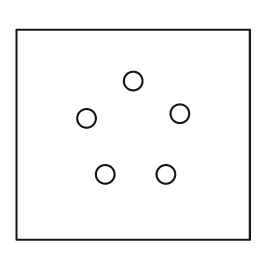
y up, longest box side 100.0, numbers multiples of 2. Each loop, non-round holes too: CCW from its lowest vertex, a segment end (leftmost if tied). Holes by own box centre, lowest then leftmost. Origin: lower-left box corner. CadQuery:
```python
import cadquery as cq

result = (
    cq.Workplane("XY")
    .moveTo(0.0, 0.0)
    .lineTo(100.0, 0.0)
    .lineTo(100.0, 90.0)
    .lineTo(0.0, 90.0)
    .close()
    .moveTo(38.0, 28.0)
    .circle(4.0)
    .moveTo(64.0, 28.0)
    .circle(4.0)
    .moveTo(30.0, 52.0)
    .circle(4.0)
    .moveTo(70.0, 54.0)
    .circle(4.0)
    .moveTo(50.0, 68.0)
    .circle(4.0)
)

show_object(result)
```